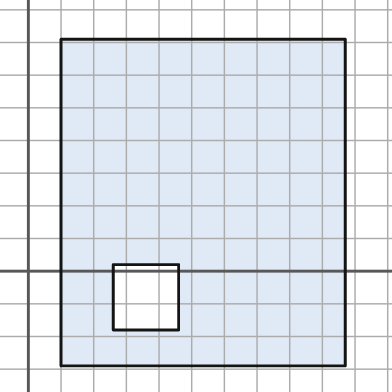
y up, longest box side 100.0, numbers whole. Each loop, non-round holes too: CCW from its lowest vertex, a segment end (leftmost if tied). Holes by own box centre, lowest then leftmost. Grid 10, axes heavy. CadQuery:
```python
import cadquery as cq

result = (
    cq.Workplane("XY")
    .moveTo(10.0, -29.0)
    .lineTo(97.0, -29.0)
    .lineTo(97.0, 71.0)
    .lineTo(10.0, 71.0)
    .close()
    .moveTo(26.0, -18.0)
    .lineTo(46.0, -18.0)
    .lineTo(46.0, 2.0)
    .lineTo(26.0, 2.0)
    .close()
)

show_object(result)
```